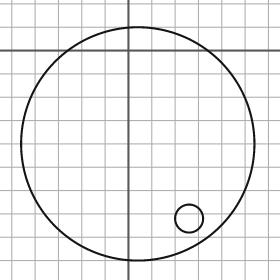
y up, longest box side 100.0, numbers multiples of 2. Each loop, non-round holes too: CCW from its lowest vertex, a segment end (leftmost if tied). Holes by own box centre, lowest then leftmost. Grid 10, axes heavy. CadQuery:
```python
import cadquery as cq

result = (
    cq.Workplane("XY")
    .moveTo(4.0, -40.0)
    .circle(50.0)
    .moveTo(26.0, -72.0)
    .circle(6.0)
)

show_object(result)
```